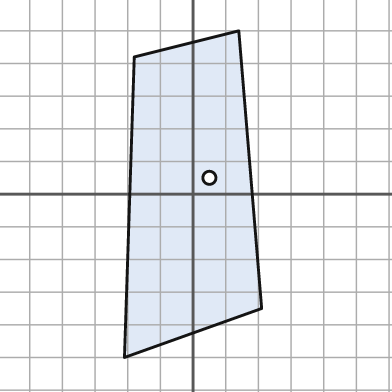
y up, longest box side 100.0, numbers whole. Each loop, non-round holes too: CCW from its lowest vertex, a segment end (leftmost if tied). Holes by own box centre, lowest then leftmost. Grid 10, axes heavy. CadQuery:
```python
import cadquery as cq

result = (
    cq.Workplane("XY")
    .moveTo(-21.0, -50.0)
    .lineTo(21.0, -35.0)
    .lineTo(14.0, 50.0)
    .lineTo(-18.0, 42.0)
    .close()
    .moveTo(5.0, 5.0)
    .circle(2.0)
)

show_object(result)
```